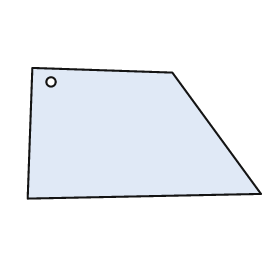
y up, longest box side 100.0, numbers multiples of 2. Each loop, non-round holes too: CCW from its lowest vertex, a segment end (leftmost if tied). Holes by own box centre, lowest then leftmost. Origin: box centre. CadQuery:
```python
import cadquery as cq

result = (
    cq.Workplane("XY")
    .moveTo(-50.0, -28.0)
    .lineTo(50.0, -26.0)
    .lineTo(12.0, 26.0)
    .lineTo(-48.0, 28.0)
    .close()
    .moveTo(-40.0, 22.0)
    .circle(2.0)
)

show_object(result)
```